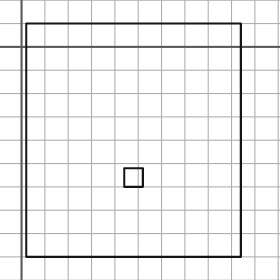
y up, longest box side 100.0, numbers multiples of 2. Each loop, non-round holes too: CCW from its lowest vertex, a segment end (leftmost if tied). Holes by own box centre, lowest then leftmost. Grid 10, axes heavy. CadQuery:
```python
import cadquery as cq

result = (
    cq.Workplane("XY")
    .moveTo(2.0, -90.0)
    .lineTo(94.0, -90.0)
    .lineTo(94.0, 10.0)
    .lineTo(2.0, 10.0)
    .close()
    .moveTo(44.0, -60.0)
    .lineTo(52.0, -60.0)
    .lineTo(52.0, -52.0)
    .lineTo(44.0, -52.0)
    .close()
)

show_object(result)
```